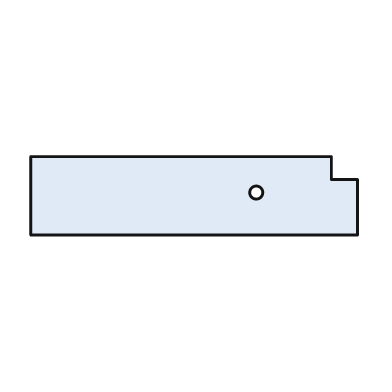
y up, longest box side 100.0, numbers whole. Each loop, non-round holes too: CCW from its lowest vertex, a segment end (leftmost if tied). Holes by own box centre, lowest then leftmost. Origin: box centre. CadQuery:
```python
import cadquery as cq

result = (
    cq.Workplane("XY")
    .moveTo(-50.0, -12.0)
    .lineTo(50.0, -12.0)
    .lineTo(50.0, 5.0)
    .lineTo(42.0, 5.0)
    .lineTo(42.0, 12.0)
    .lineTo(-50.0, 12.0)
    .close()
    .moveTo(19.0, 1.0)
    .circle(2.0)
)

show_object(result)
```